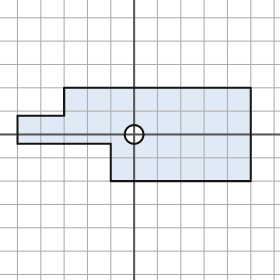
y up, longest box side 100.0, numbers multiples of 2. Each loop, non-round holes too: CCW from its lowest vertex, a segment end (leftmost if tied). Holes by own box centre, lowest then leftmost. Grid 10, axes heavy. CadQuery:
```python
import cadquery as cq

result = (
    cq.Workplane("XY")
    .moveTo(-10.0, -20.0)
    .lineTo(50.0, -20.0)
    .lineTo(50.0, 20.0)
    .lineTo(-30.0, 20.0)
    .lineTo(-30.0, 8.0)
    .lineTo(-50.0, 8.0)
    .lineTo(-50.0, -4.0)
    .lineTo(-10.0, -4.0)
    .close()
    .moveTo(0.0, 0.0)
    .circle(4.0)
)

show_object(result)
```